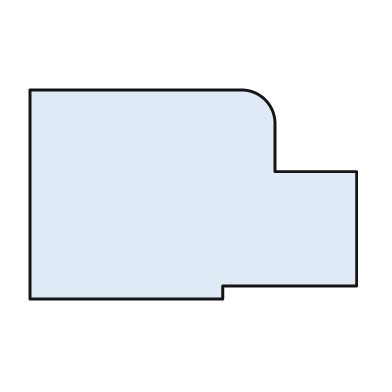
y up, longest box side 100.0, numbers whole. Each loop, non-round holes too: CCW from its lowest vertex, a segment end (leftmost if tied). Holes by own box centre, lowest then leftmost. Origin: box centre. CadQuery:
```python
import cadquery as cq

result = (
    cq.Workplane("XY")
    .moveTo(-50.0, -32.0)
    .lineTo(9.0, -32.0)
    .lineTo(9.0, -28.0)
    .lineTo(50.0, -28.0)
    .lineTo(50.0, 7.0)
    .lineTo(25.0, 7.0)
    .lineTo(25.0, 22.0)
    .threePointArc((22.0, 29.0), (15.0, 32.0))
    .lineTo(-50.0, 32.0)
    .close()
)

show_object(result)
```